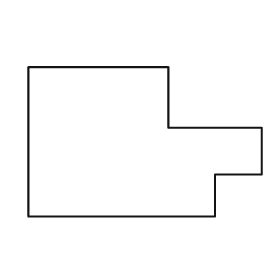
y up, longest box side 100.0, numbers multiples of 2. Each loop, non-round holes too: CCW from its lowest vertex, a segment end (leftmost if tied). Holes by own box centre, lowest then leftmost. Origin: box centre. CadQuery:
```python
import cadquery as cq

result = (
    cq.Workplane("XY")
    .moveTo(-50.0, -32.0)
    .lineTo(30.0, -32.0)
    .lineTo(30.0, -14.0)
    .lineTo(50.0, -14.0)
    .lineTo(50.0, 6.0)
    .lineTo(10.0, 6.0)
    .lineTo(10.0, 32.0)
    .lineTo(-50.0, 32.0)
    .close()
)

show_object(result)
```